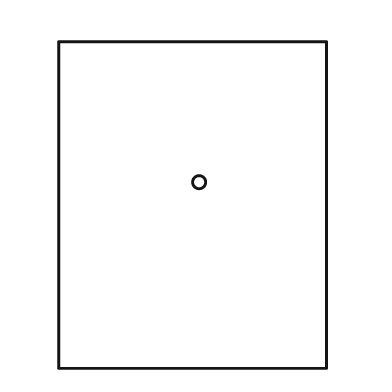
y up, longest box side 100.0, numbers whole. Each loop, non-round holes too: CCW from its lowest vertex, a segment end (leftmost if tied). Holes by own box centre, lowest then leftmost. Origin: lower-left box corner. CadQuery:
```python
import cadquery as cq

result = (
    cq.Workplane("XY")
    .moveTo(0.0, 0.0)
    .lineTo(82.0, 0.0)
    .lineTo(82.0, 100.0)
    .lineTo(0.0, 100.0)
    .close()
    .moveTo(43.0, 57.0)
    .circle(2.0)
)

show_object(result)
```